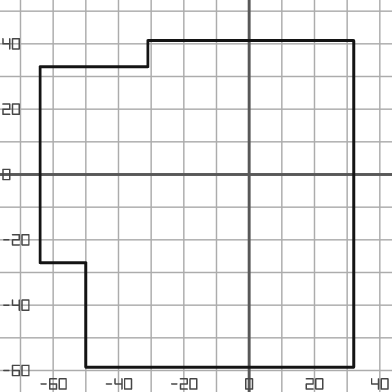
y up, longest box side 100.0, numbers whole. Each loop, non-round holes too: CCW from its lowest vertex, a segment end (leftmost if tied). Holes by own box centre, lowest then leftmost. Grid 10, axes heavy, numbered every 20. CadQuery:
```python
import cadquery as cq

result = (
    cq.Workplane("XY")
    .moveTo(-50.0, -59.0)
    .lineTo(32.0, -59.0)
    .lineTo(32.0, 41.0)
    .lineTo(-31.0, 41.0)
    .lineTo(-31.0, 33.0)
    .lineTo(-64.0, 33.0)
    .lineTo(-64.0, -27.0)
    .lineTo(-50.0, -27.0)
    .close()
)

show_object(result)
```